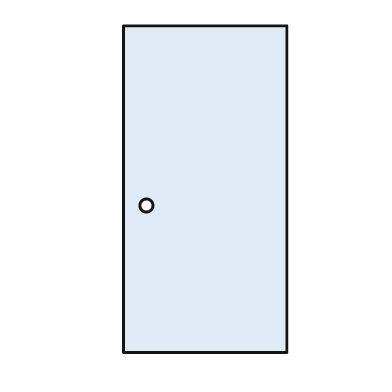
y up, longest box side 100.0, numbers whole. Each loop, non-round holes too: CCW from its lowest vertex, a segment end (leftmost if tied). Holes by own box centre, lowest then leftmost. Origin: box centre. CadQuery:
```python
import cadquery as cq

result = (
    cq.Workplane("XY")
    .moveTo(-25.0, -50.0)
    .lineTo(25.0, -50.0)
    .lineTo(25.0, 50.0)
    .lineTo(-25.0, 50.0)
    .close()
    .moveTo(-18.0, -5.0)
    .circle(2.0)
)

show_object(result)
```